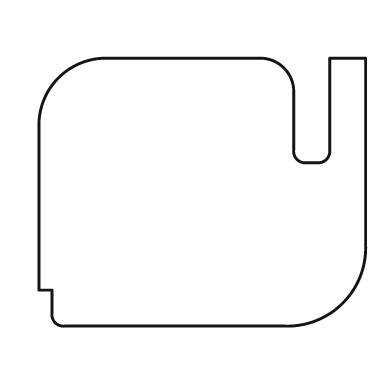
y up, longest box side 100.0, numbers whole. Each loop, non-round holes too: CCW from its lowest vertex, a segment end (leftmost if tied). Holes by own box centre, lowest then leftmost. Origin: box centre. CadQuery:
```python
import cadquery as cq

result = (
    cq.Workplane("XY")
    .moveTo(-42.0, -41.0)
    .lineTo(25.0, -41.0)
    .threePointArc((43.0, -34.0), (50.0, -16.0))
    .lineTo(50.0, 41.0)
    .lineTo(39.0, 41.0)
    .lineTo(39.0, 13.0)
    .threePointArc((38.0, 10.0), (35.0, 9.0))
    .lineTo(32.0, 9.0)
    .threePointArc((29.0, 10.0), (28.0, 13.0))
    .lineTo(28.0, 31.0)
    .threePointArc((25.0, 38.0), (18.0, 41.0))
    .lineTo(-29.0, 41.0)
    .threePointArc((-44.0, 35.0), (-50.0, 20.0))
    .lineTo(-50.0, -30.0)
    .lineTo(-46.0, -30.0)
    .lineTo(-46.0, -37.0)
    .threePointArc((-45.0, -40.0), (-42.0, -41.0))
    .close()
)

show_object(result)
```